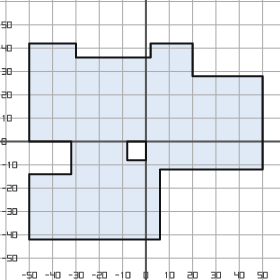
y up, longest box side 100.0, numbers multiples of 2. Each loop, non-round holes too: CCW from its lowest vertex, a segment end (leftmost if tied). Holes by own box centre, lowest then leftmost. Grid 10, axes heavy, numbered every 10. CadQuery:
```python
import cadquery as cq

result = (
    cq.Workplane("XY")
    .moveTo(-50.0, -42.0)
    .lineTo(6.0, -42.0)
    .lineTo(6.0, -12.0)
    .lineTo(50.0, -12.0)
    .lineTo(50.0, 28.0)
    .lineTo(20.0, 28.0)
    .lineTo(20.0, 42.0)
    .lineTo(2.0, 42.0)
    .lineTo(2.0, 36.0)
    .lineTo(-30.0, 36.0)
    .lineTo(-30.0, 42.0)
    .lineTo(-50.0, 42.0)
    .lineTo(-50.0, 0.0)
    .lineTo(-32.0, 0.0)
    .lineTo(-32.0, -14.0)
    .lineTo(-50.0, -14.0)
    .close()
    .moveTo(-8.0, -8.0)
    .lineTo(0.0, -8.0)
    .lineTo(0.0, 0.0)
    .lineTo(-8.0, 0.0)
    .close()
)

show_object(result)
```